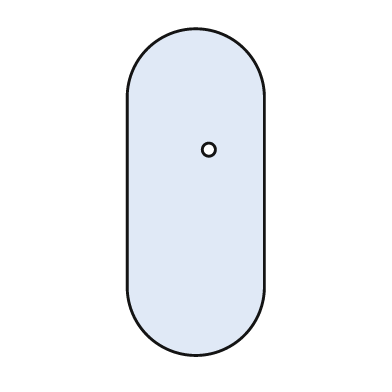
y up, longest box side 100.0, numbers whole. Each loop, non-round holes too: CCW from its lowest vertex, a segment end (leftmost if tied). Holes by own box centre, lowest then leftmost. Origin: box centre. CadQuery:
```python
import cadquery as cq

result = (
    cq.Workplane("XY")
    .moveTo(-21.0, -29.0)
    .threePointArc((0.0, -50.0), (21.0, -29.0))
    .lineTo(21.0, 29.0)
    .threePointArc((0.0, 50.0), (-21.0, 29.0))
    .close()
    .moveTo(4.0, 13.0)
    .circle(2.0)
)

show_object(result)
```